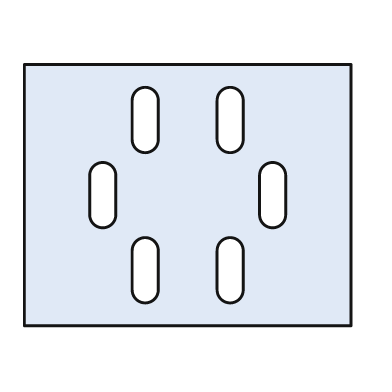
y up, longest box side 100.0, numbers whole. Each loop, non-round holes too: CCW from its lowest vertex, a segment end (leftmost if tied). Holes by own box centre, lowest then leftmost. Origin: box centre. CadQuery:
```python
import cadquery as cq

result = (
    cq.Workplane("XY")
    .moveTo(-50.0, -40.0)
    .lineTo(50.0, -40.0)
    .lineTo(50.0, 40.0)
    .lineTo(-50.0, 40.0)
    .close()
    .moveTo(-17.0, -29.0)
    .threePointArc((-13.0, -33.0), (-9.0, -29.0))
    .lineTo(-9.0, -17.0)
    .threePointArc((-13.0, -13.0), (-17.0, -17.0))
    .close()
    .moveTo(9.0, -29.0)
    .threePointArc((13.0, -33.0), (17.0, -29.0))
    .lineTo(17.0, -17.0)
    .threePointArc((13.0, -13.0), (9.0, -17.0))
    .close()
    .moveTo(-30.0, -6.0)
    .threePointArc((-26.0, -10.0), (-22.0, -6.0))
    .lineTo(-22.0, 6.0)
    .threePointArc((-26.0, 10.0), (-30.0, 6.0))
    .close()
    .moveTo(22.0, -6.0)
    .threePointArc((26.0, -10.0), (30.0, -6.0))
    .lineTo(30.0, 6.0)
    .threePointArc((26.0, 10.0), (22.0, 6.0))
    .close()
    .moveTo(-17.0, 17.0)
    .threePointArc((-13.0, 13.0), (-9.0, 17.0))
    .lineTo(-9.0, 29.0)
    .threePointArc((-13.0, 33.0), (-17.0, 29.0))
    .close()
    .moveTo(9.0, 17.0)
    .threePointArc((13.0, 13.0), (17.0, 17.0))
    .lineTo(17.0, 29.0)
    .threePointArc((13.0, 33.0), (9.0, 29.0))
    .close()
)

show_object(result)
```